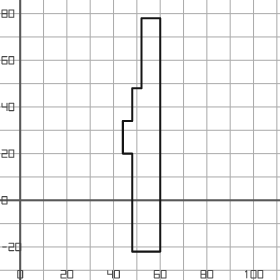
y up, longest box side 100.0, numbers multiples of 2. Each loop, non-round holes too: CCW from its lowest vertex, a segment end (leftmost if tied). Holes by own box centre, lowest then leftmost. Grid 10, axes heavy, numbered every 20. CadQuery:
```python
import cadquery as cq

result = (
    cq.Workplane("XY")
    .moveTo(48.0, -22.0)
    .lineTo(60.0, -22.0)
    .lineTo(60.0, 78.0)
    .lineTo(52.0, 78.0)
    .lineTo(52.0, 48.0)
    .lineTo(48.0, 48.0)
    .lineTo(48.0, 34.0)
    .lineTo(44.0, 34.0)
    .lineTo(44.0, 20.0)
    .lineTo(48.0, 20.0)
    .close()
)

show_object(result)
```